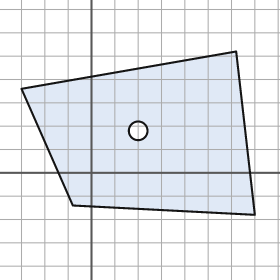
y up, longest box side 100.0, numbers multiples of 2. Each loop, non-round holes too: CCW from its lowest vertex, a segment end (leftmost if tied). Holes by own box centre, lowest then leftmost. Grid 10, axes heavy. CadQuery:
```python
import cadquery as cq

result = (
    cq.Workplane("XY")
    .moveTo(70.0, -18.0)
    .lineTo(62.0, 52.0)
    .lineTo(-30.0, 36.0)
    .lineTo(-8.0, -14.0)
    .close()
    .moveTo(20.0, 18.0)
    .circle(4.0)
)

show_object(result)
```